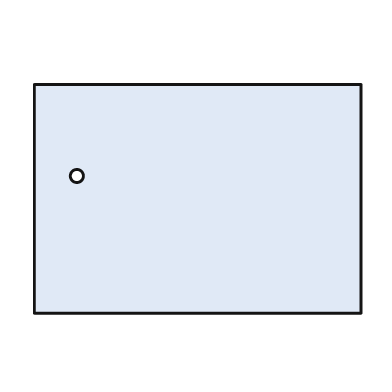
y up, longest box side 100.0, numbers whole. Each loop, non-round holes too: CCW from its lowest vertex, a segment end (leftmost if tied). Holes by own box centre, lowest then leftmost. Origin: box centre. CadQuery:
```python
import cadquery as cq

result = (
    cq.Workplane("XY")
    .moveTo(-50.0, -35.0)
    .lineTo(50.0, -35.0)
    .lineTo(50.0, 35.0)
    .lineTo(-50.0, 35.0)
    .close()
    .moveTo(-37.0, 7.0)
    .circle(2.0)
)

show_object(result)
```